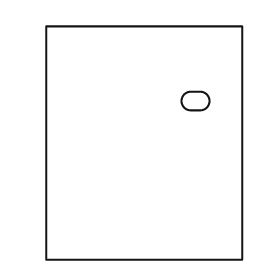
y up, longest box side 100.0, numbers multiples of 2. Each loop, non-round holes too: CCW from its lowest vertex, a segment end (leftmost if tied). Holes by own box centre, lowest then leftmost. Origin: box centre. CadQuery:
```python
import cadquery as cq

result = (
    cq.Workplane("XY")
    .moveTo(-42.0, -50.0)
    .lineTo(42.0, -50.0)
    .lineTo(42.0, 50.0)
    .lineTo(-42.0, 50.0)
    .close()
    .moveTo(20.0, 14.0)
    .lineTo(24.0, 14.0)
    .threePointArc((28.0, 18.0), (24.0, 22.0))
    .lineTo(20.0, 22.0)
    .threePointArc((16.0, 18.0), (20.0, 14.0))
    .close()
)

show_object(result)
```